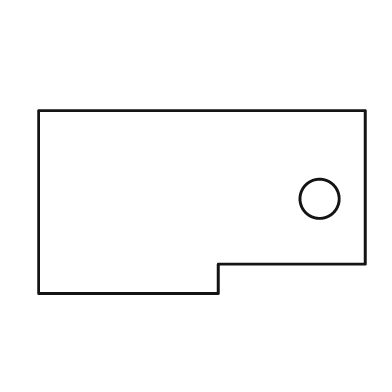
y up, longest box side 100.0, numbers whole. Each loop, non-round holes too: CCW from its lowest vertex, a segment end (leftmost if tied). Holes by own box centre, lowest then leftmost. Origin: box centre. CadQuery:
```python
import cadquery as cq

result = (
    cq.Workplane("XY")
    .moveTo(-50.0, -28.0)
    .lineTo(5.0, -28.0)
    .lineTo(5.0, -19.0)
    .lineTo(50.0, -19.0)
    .lineTo(50.0, 28.0)
    .lineTo(-50.0, 28.0)
    .close()
    .moveTo(36.0, 1.0)
    .circle(6.0)
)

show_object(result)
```